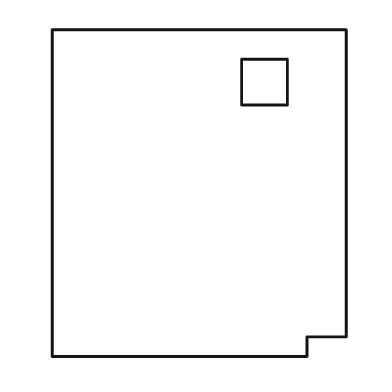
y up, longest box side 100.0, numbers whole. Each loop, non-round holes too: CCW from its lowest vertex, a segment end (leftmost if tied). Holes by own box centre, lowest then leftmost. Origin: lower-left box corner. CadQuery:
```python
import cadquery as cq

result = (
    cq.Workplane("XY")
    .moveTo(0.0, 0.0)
    .lineTo(78.0, 0.0)
    .lineTo(78.0, 6.0)
    .lineTo(90.0, 6.0)
    .lineTo(90.0, 100.0)
    .lineTo(0.0, 100.0)
    .close()
    .moveTo(58.0, 77.0)
    .lineTo(72.0, 77.0)
    .lineTo(72.0, 91.0)
    .lineTo(58.0, 91.0)
    .close()
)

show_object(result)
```